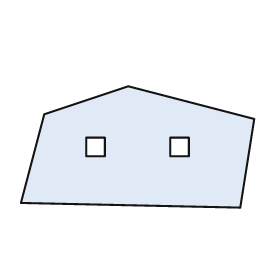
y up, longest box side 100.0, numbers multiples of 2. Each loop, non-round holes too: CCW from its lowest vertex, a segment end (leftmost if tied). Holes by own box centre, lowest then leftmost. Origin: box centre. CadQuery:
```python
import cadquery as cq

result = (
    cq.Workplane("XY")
    .moveTo(44.0, -26.0)
    .lineTo(50.0, 12.0)
    .lineTo(-4.0, 26.0)
    .lineTo(-40.0, 14.0)
    .lineTo(-50.0, -24.0)
    .close()
    .moveTo(-22.0, -4.0)
    .lineTo(-14.0, -4.0)
    .lineTo(-14.0, 4.0)
    .lineTo(-22.0, 4.0)
    .close()
    .moveTo(14.0, -4.0)
    .lineTo(22.0, -4.0)
    .lineTo(22.0, 4.0)
    .lineTo(14.0, 4.0)
    .close()
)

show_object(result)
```